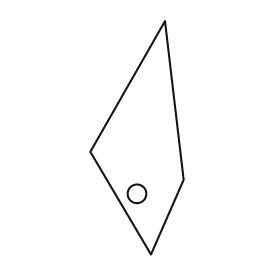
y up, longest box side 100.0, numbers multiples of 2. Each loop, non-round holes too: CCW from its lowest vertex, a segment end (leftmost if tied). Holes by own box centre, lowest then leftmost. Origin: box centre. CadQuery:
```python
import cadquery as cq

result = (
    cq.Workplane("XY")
    .moveTo(6.0, -50.0)
    .lineTo(20.0, -18.0)
    .lineTo(12.0, 50.0)
    .lineTo(-20.0, -6.0)
    .close()
    .moveTo(0.0, -24.0)
    .circle(4.0)
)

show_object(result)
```